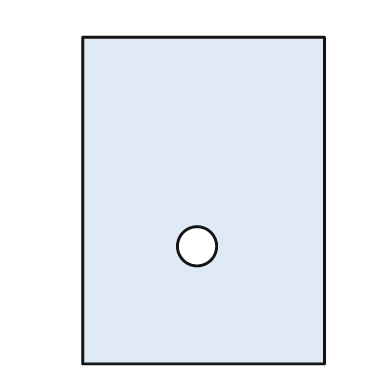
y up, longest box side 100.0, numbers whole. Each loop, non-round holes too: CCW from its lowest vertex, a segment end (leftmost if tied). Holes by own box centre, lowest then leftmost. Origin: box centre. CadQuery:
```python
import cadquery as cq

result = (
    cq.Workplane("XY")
    .moveTo(-37.0, -50.0)
    .lineTo(37.0, -50.0)
    .lineTo(37.0, 50.0)
    .lineTo(-37.0, 50.0)
    .close()
    .moveTo(-2.0, -14.0)
    .circle(6.0)
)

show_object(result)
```